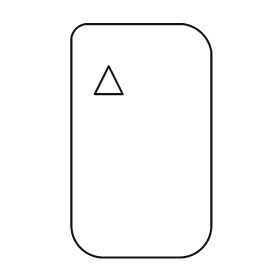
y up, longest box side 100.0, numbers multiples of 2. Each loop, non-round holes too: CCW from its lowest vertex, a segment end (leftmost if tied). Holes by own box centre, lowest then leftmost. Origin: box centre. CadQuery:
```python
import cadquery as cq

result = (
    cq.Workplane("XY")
    .moveTo(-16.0, -50.0)
    .lineTo(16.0, -50.0)
    .threePointArc((26.0, -46.0), (30.0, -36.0))
    .lineTo(30.0, 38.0)
    .threePointArc((26.0, 46.0), (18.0, 50.0))
    .lineTo(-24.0, 50.0)
    .threePointArc((-28.0, 48.0), (-30.0, 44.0))
    .lineTo(-30.0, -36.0)
    .threePointArc((-26.0, -46.0), (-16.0, -50.0))
    .close()
    .moveTo(-20.0, 20.0)
    .lineTo(-8.0, 20.0)
    .lineTo(-14.0, 32.0)
    .close()
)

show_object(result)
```